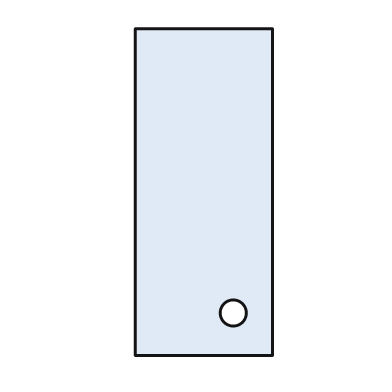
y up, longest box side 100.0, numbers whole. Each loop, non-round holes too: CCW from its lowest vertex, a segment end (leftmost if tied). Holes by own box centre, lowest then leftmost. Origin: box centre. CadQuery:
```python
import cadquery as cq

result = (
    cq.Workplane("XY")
    .moveTo(-21.0, -50.0)
    .lineTo(21.0, -50.0)
    .lineTo(21.0, 50.0)
    .lineTo(-21.0, 50.0)
    .close()
    .moveTo(9.0, -37.0)
    .circle(4.0)
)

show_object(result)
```